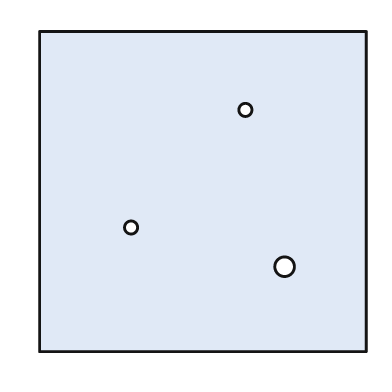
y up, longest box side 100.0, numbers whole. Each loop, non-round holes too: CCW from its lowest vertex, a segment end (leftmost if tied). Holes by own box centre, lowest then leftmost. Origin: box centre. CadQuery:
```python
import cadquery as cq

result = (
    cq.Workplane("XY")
    .moveTo(-50.0, -49.0)
    .lineTo(50.0, -49.0)
    .lineTo(50.0, 49.0)
    .lineTo(-50.0, 49.0)
    .close()
    .moveTo(25.0, -23.0)
    .circle(3.0)
    .moveTo(-22.0, -11.0)
    .circle(2.0)
    .moveTo(13.0, 25.0)
    .circle(2.0)
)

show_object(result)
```